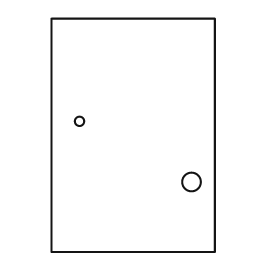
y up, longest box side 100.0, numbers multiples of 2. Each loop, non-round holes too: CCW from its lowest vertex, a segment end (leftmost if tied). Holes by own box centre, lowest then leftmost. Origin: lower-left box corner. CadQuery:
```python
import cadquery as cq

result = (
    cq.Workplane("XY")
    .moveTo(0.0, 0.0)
    .lineTo(70.0, 0.0)
    .lineTo(70.0, 100.0)
    .lineTo(0.0, 100.0)
    .close()
    .moveTo(60.0, 30.0)
    .circle(4.0)
    .moveTo(12.0, 56.0)
    .circle(2.0)
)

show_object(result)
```